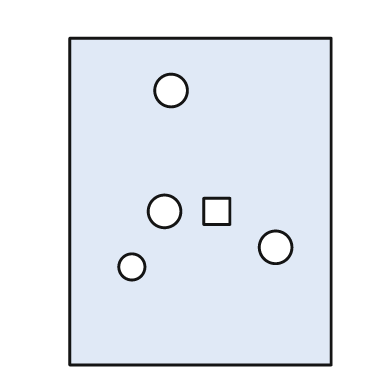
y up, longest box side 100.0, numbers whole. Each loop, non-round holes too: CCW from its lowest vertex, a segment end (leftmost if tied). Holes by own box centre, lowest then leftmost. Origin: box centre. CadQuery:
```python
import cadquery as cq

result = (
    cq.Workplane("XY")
    .moveTo(-40.0, -50.0)
    .lineTo(40.0, -50.0)
    .lineTo(40.0, 50.0)
    .lineTo(-40.0, 50.0)
    .close()
    .moveTo(-21.0, -20.0)
    .circle(4.0)
    .moveTo(23.0, -14.0)
    .circle(5.0)
    .moveTo(-11.0, -3.0)
    .circle(5.0)
    .moveTo(1.0, -7.0)
    .lineTo(9.0, -7.0)
    .lineTo(9.0, 1.0)
    .lineTo(1.0, 1.0)
    .close()
    .moveTo(-9.0, 34.0)
    .circle(5.0)
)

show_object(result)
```